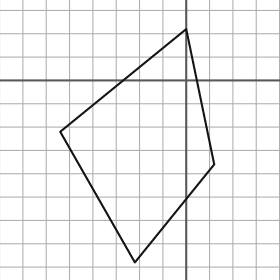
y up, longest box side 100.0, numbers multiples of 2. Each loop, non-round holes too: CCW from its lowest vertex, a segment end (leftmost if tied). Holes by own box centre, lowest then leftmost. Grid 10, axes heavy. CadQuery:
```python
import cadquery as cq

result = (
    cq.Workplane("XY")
    .moveTo(-22.0, -78.0)
    .lineTo(12.0, -36.0)
    .lineTo(0.0, 22.0)
    .lineTo(-54.0, -22.0)
    .close()
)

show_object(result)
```